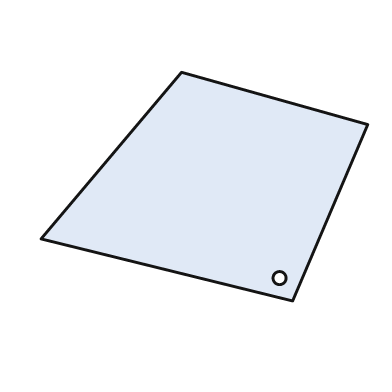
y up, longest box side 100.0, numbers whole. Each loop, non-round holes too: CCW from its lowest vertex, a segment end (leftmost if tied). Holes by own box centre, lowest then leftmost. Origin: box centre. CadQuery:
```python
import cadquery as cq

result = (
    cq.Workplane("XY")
    .moveTo(27.0, -35.0)
    .lineTo(50.0, 19.0)
    .lineTo(-7.0, 35.0)
    .lineTo(-50.0, -16.0)
    .close()
    .moveTo(23.0, -28.0)
    .circle(2.0)
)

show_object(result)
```